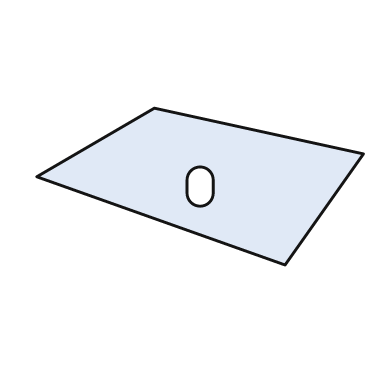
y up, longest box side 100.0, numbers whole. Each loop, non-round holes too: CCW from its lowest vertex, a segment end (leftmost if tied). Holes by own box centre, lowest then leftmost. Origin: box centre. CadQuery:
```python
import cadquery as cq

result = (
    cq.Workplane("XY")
    .moveTo(26.0, -24.0)
    .lineTo(50.0, 10.0)
    .lineTo(-14.0, 24.0)
    .lineTo(-50.0, 3.0)
    .close()
    .moveTo(-4.0, -2.0)
    .threePointArc((0.0, -6.0), (4.0, -2.0))
    .lineTo(4.0, 2.0)
    .threePointArc((0.0, 6.0), (-4.0, 2.0))
    .close()
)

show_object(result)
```